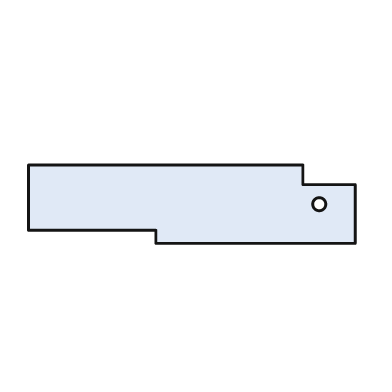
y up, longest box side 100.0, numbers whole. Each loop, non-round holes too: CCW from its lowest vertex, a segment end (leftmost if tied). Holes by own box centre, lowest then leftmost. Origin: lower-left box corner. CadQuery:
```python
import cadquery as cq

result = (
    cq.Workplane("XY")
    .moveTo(39.0, 0.0)
    .lineTo(100.0, 0.0)
    .lineTo(100.0, 18.0)
    .lineTo(84.0, 18.0)
    .lineTo(84.0, 24.0)
    .lineTo(0.0, 24.0)
    .lineTo(0.0, 4.0)
    .lineTo(39.0, 4.0)
    .close()
    .moveTo(89.0, 12.0)
    .circle(2.0)
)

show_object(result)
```